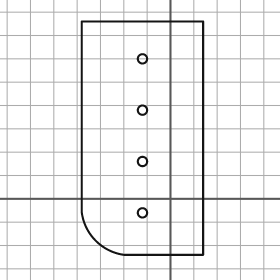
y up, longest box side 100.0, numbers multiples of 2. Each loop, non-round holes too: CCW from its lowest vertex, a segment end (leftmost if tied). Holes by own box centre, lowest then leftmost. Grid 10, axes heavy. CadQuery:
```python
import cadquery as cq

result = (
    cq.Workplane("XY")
    .moveTo(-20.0, -24.0)
    .lineTo(14.0, -24.0)
    .lineTo(14.0, 76.0)
    .lineTo(-38.0, 76.0)
    .lineTo(-38.0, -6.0)
    .threePointArc((-32.0, -18.0), (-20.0, -24.0))
    .close()
    .moveTo(-12.0, -6.0)
    .circle(2.0)
    .moveTo(-12.0, 16.0)
    .circle(2.0)
    .moveTo(-12.0, 38.0)
    .circle(2.0)
    .moveTo(-12.0, 60.0)
    .circle(2.0)
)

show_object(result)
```